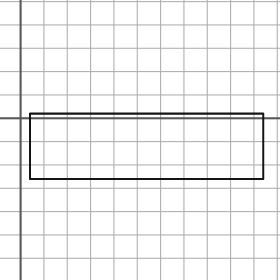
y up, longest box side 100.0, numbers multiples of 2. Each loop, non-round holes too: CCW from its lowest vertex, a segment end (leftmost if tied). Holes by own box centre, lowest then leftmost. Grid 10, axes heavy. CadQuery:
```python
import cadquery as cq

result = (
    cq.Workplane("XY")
    .moveTo(4.0, -26.0)
    .lineTo(104.0, -26.0)
    .lineTo(104.0, 2.0)
    .lineTo(4.0, 2.0)
    .close()
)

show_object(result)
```